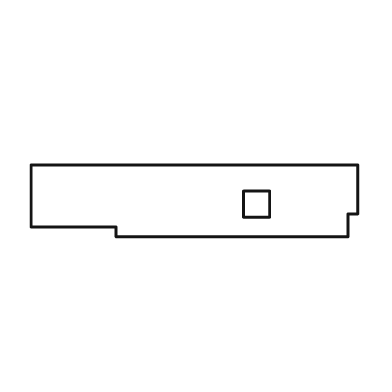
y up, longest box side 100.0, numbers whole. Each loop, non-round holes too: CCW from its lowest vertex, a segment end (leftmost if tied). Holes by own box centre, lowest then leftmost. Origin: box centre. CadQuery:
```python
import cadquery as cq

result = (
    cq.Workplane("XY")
    .moveTo(-24.0, -11.0)
    .lineTo(47.0, -11.0)
    .lineTo(47.0, -4.0)
    .lineTo(50.0, -4.0)
    .lineTo(50.0, 11.0)
    .lineTo(-50.0, 11.0)
    .lineTo(-50.0, -8.0)
    .lineTo(-24.0, -8.0)
    .close()
    .moveTo(15.0, -5.0)
    .lineTo(23.0, -5.0)
    .lineTo(23.0, 3.0)
    .lineTo(15.0, 3.0)
    .close()
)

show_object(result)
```